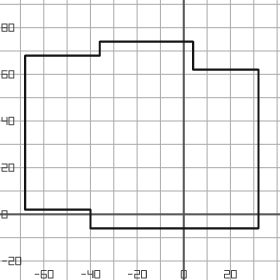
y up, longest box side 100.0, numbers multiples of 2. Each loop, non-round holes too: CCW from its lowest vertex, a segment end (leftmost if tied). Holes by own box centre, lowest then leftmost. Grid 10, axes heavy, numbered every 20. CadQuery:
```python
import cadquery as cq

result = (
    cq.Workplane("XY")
    .moveTo(-40.0, -6.0)
    .lineTo(32.0, -6.0)
    .lineTo(32.0, 62.0)
    .lineTo(4.0, 62.0)
    .lineTo(4.0, 74.0)
    .lineTo(-36.0, 74.0)
    .lineTo(-36.0, 68.0)
    .lineTo(-68.0, 68.0)
    .lineTo(-68.0, 2.0)
    .lineTo(-40.0, 2.0)
    .close()
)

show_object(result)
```